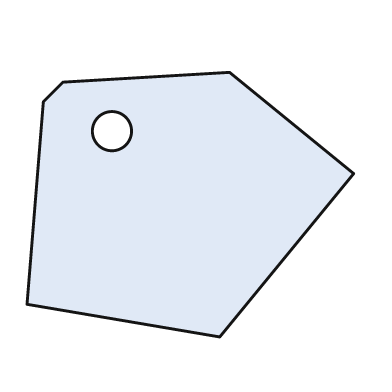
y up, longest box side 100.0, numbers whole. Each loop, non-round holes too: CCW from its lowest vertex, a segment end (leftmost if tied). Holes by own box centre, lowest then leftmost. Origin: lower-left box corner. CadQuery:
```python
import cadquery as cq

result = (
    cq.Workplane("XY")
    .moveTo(59.0, 0.0)
    .lineTo(100.0, 50.0)
    .lineTo(62.0, 81.0)
    .lineTo(11.0, 78.0)
    .lineTo(5.0, 72.0)
    .lineTo(0.0, 10.0)
    .close()
    .moveTo(26.0, 63.0)
    .circle(6.0)
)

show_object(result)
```